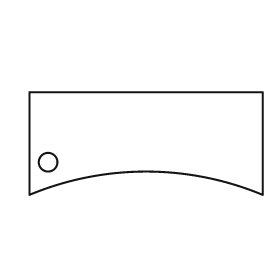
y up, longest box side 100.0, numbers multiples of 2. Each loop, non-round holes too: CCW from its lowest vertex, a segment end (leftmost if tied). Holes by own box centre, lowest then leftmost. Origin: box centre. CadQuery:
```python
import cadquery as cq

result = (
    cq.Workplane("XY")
    .moveTo(-50.0, -22.0)
    .threePointArc((0.0, -12.0), (50.0, -22.0))
    .lineTo(50.0, 22.0)
    .lineTo(-50.0, 22.0)
    .close()
    .moveTo(-42.0, -8.0)
    .circle(4.0)
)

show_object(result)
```